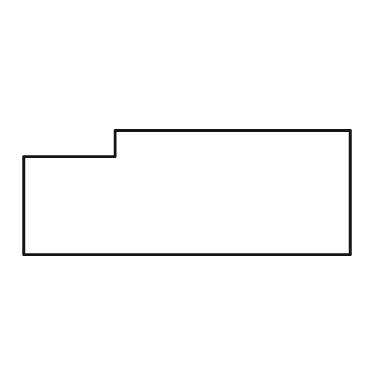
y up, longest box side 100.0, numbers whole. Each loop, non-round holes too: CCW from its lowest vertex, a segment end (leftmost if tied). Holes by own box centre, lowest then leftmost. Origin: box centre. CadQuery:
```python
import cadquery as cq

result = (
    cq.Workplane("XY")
    .moveTo(-50.0, -19.0)
    .lineTo(50.0, -19.0)
    .lineTo(50.0, 19.0)
    .lineTo(-22.0, 19.0)
    .lineTo(-22.0, 11.0)
    .lineTo(-50.0, 11.0)
    .close()
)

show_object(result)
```